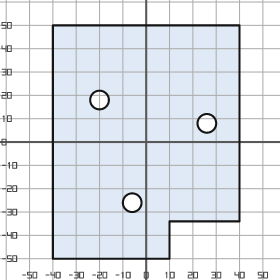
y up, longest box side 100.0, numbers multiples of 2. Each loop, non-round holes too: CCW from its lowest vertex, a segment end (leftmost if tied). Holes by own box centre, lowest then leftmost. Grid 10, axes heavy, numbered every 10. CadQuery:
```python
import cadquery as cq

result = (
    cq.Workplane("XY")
    .moveTo(-40.0, -50.0)
    .lineTo(10.0, -50.0)
    .lineTo(10.0, -34.0)
    .lineTo(40.0, -34.0)
    .lineTo(40.0, 50.0)
    .lineTo(-40.0, 50.0)
    .close()
    .moveTo(-6.0, -26.0)
    .circle(4.0)
    .moveTo(26.0, 8.0)
    .circle(4.0)
    .moveTo(-20.0, 18.0)
    .circle(4.0)
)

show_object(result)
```